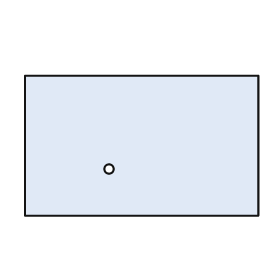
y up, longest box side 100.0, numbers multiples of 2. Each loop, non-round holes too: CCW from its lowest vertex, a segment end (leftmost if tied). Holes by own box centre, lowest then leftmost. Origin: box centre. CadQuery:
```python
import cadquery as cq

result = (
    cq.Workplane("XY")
    .moveTo(-50.0, -30.0)
    .lineTo(50.0, -30.0)
    .lineTo(50.0, 30.0)
    .lineTo(-50.0, 30.0)
    .close()
    .moveTo(-14.0, -10.0)
    .circle(2.0)
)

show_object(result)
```